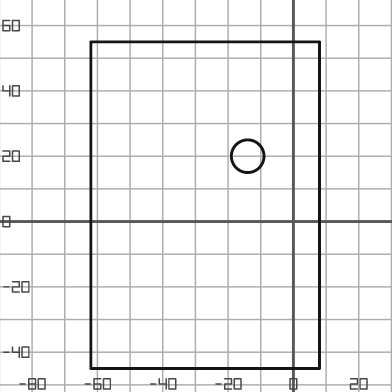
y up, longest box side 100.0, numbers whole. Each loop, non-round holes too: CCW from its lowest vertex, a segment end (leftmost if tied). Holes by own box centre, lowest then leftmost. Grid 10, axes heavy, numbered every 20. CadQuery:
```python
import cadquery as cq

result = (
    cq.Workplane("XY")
    .moveTo(-62.0, -45.0)
    .lineTo(8.0, -45.0)
    .lineTo(8.0, 55.0)
    .lineTo(-62.0, 55.0)
    .close()
    .moveTo(-14.0, 20.0)
    .circle(5.0)
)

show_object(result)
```